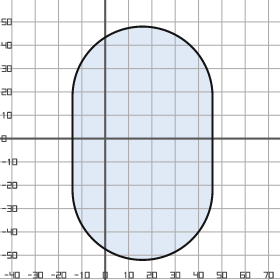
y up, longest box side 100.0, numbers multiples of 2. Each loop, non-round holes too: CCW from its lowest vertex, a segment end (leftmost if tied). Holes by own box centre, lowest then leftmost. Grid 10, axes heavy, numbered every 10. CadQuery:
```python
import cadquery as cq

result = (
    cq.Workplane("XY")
    .moveTo(-14.0, -22.0)
    .threePointArc((16.0, -52.0), (46.0, -22.0))
    .lineTo(46.0, 18.0)
    .threePointArc((16.0, 48.0), (-14.0, 18.0))
    .close()
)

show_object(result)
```